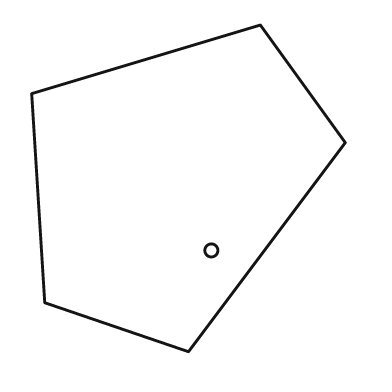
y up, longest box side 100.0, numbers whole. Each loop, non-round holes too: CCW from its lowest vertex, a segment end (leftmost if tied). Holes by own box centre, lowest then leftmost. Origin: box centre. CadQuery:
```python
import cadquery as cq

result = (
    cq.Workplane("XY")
    .moveTo(0.0, -50.0)
    .lineTo(48.0, 14.0)
    .lineTo(22.0, 50.0)
    .lineTo(-48.0, 29.0)
    .lineTo(-44.0, -35.0)
    .close()
    .moveTo(7.0, -19.0)
    .circle(2.0)
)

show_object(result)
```